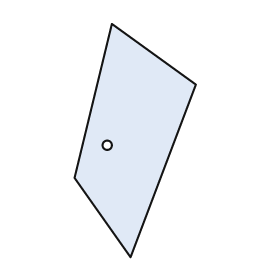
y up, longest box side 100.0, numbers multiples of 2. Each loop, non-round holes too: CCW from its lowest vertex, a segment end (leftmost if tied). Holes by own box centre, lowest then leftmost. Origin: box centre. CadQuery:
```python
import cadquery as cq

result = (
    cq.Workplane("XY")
    .moveTo(-2.0, -50.0)
    .lineTo(26.0, 24.0)
    .lineTo(-10.0, 50.0)
    .lineTo(-26.0, -16.0)
    .close()
    .moveTo(-12.0, -2.0)
    .circle(2.0)
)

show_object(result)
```